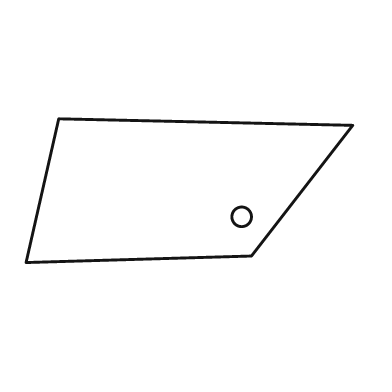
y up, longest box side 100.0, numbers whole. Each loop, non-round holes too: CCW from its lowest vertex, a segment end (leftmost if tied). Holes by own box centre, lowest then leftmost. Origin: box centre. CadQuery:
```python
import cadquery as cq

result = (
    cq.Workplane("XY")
    .moveTo(-50.0, -22.0)
    .lineTo(19.0, -20.0)
    .lineTo(50.0, 20.0)
    .lineTo(-40.0, 22.0)
    .close()
    .moveTo(16.0, -8.0)
    .circle(3.0)
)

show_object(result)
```